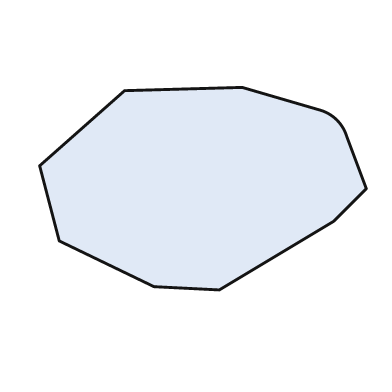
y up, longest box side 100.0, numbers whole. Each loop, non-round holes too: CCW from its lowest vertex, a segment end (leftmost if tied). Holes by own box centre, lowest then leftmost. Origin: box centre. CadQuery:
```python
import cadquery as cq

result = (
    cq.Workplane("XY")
    .moveTo(5.0, -31.0)
    .lineTo(40.0, -10.0)
    .lineTo(50.0, 0.0)
    .lineTo(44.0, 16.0)
    .threePointArc((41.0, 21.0), (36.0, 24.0))
    .lineTo(12.0, 31.0)
    .lineTo(-24.0, 30.0)
    .lineTo(-50.0, 7.0)
    .lineTo(-44.0, -16.0)
    .lineTo(-15.0, -30.0)
    .close()
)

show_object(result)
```